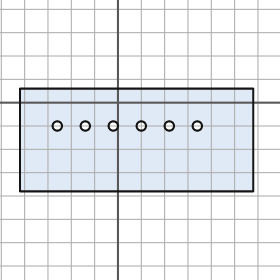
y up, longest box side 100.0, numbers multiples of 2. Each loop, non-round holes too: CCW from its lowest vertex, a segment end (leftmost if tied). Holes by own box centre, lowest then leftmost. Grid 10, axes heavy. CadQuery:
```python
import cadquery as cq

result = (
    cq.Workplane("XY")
    .moveTo(-42.0, -38.0)
    .lineTo(58.0, -38.0)
    .lineTo(58.0, 6.0)
    .lineTo(-42.0, 6.0)
    .close()
    .moveTo(-26.0, -10.0)
    .circle(2.0)
    .moveTo(-14.0, -10.0)
    .circle(2.0)
    .moveTo(-2.0, -10.0)
    .circle(2.0)
    .moveTo(10.0, -10.0)
    .circle(2.0)
    .moveTo(22.0, -10.0)
    .circle(2.0)
    .moveTo(34.0, -10.0)
    .circle(2.0)
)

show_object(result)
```